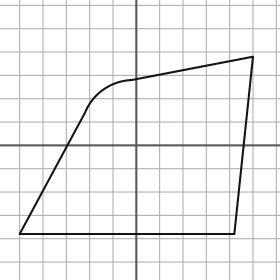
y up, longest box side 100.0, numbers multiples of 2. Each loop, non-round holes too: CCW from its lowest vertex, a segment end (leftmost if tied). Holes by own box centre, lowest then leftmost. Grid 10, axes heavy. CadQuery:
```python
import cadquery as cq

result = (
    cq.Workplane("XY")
    .moveTo(-50.0, -38.0)
    .lineTo(42.0, -38.0)
    .lineTo(50.0, 38.0)
    .lineTo(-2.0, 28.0)
    .threePointArc((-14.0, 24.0), (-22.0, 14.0))
    .close()
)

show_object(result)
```